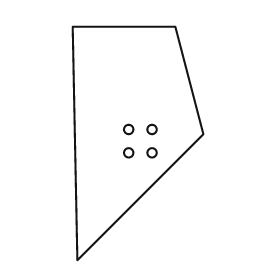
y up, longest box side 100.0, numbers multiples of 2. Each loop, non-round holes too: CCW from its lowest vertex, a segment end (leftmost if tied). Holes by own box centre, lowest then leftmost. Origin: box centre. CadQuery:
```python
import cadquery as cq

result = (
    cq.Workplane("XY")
    .moveTo(-26.0, -50.0)
    .lineTo(28.0, 4.0)
    .lineTo(16.0, 50.0)
    .lineTo(-28.0, 50.0)
    .close()
    .moveTo(-4.0, -4.0)
    .circle(2.0)
    .moveTo(6.0, -4.0)
    .circle(2.0)
    .moveTo(-4.0, 6.0)
    .circle(2.0)
    .moveTo(6.0, 6.0)
    .circle(2.0)
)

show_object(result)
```